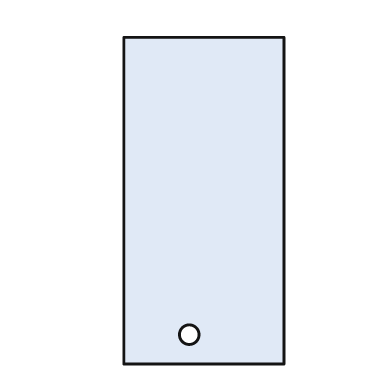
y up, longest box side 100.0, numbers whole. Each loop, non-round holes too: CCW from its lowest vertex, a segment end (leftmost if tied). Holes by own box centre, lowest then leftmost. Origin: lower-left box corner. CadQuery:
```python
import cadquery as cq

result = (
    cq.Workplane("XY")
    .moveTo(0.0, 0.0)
    .lineTo(49.0, 0.0)
    .lineTo(49.0, 100.0)
    .lineTo(0.0, 100.0)
    .close()
    .moveTo(20.0, 9.0)
    .circle(3.0)
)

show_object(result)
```